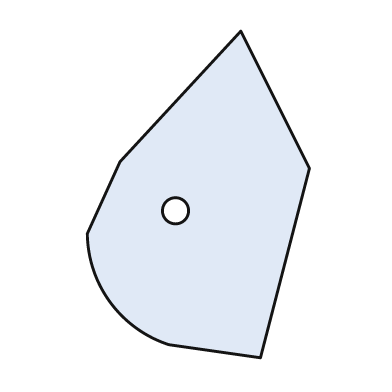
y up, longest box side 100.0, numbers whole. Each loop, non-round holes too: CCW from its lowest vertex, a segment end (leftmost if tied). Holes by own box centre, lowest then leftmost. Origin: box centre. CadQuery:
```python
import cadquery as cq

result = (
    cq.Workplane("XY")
    .moveTo(19.0, -50.0)
    .lineTo(34.0, 8.0)
    .lineTo(13.0, 50.0)
    .lineTo(-24.0, 10.0)
    .lineTo(-34.0, -12.0)
    .threePointArc((-27.0, -33.0), (-9.0, -46.0))
    .close()
    .moveTo(-7.0, -5.0)
    .circle(4.0)
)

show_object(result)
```